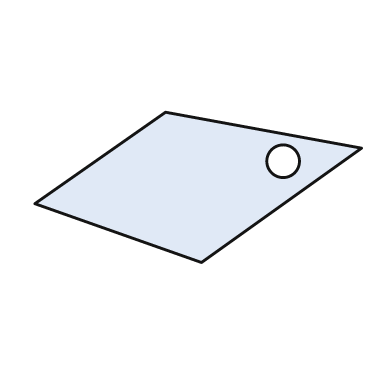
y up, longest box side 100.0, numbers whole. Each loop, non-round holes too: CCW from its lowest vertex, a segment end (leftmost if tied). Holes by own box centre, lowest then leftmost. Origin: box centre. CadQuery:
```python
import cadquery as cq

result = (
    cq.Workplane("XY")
    .moveTo(1.0, -23.0)
    .lineTo(50.0, 12.0)
    .lineTo(-10.0, 23.0)
    .lineTo(-50.0, -5.0)
    .close()
    .moveTo(26.0, 8.0)
    .circle(5.0)
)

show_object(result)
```